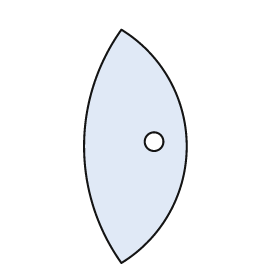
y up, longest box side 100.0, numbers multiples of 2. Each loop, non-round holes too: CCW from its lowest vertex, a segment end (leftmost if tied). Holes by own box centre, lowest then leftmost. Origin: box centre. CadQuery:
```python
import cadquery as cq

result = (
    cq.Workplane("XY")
    .moveTo(-6.0, -50.0)
    .threePointArc((22.0, 0.0), (-6.0, 50.0))
    .threePointArc((-22.0, 0.0), (-6.0, -50.0))
    .close()
    .moveTo(8.0, 2.0)
    .circle(4.0)
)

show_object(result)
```